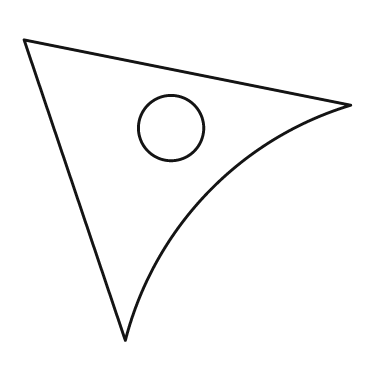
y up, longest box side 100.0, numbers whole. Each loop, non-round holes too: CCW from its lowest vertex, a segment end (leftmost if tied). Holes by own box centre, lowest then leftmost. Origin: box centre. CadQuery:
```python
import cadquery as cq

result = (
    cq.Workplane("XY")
    .moveTo(-19.0, -46.0)
    .threePointArc((6.0, -1.0), (50.0, 26.0))
    .lineTo(-50.0, 46.0)
    .close()
    .moveTo(-5.0, 19.0)
    .circle(10.0)
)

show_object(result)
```